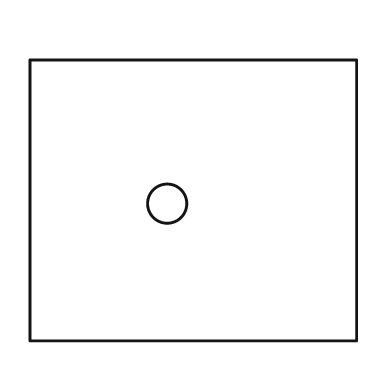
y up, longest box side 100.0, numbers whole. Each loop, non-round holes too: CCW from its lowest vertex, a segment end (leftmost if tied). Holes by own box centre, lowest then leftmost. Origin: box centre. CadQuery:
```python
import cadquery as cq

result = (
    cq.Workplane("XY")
    .moveTo(-50.0, -43.0)
    .lineTo(50.0, -43.0)
    .lineTo(50.0, 43.0)
    .lineTo(-50.0, 43.0)
    .close()
    .moveTo(-8.0, -1.0)
    .circle(6.0)
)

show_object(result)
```